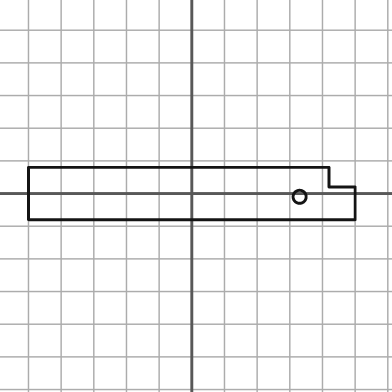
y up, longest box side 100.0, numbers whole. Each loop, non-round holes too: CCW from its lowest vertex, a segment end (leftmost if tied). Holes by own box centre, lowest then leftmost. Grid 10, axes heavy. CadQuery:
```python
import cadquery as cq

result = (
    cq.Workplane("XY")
    .moveTo(-50.0, -8.0)
    .lineTo(50.0, -8.0)
    .lineTo(50.0, 2.0)
    .lineTo(42.0, 2.0)
    .lineTo(42.0, 8.0)
    .lineTo(-50.0, 8.0)
    .close()
    .moveTo(33.0, -1.0)
    .circle(2.0)
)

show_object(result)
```